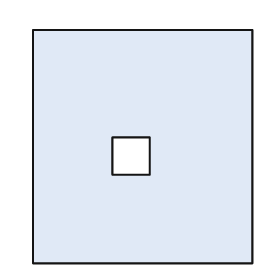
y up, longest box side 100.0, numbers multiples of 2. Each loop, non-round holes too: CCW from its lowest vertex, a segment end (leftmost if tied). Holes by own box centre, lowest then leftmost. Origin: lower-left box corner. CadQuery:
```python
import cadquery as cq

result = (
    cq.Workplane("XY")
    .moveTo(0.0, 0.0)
    .lineTo(94.0, 0.0)
    .lineTo(94.0, 100.0)
    .lineTo(0.0, 100.0)
    .close()
    .moveTo(34.0, 38.0)
    .lineTo(50.0, 38.0)
    .lineTo(50.0, 54.0)
    .lineTo(34.0, 54.0)
    .close()
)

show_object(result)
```